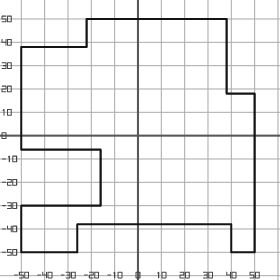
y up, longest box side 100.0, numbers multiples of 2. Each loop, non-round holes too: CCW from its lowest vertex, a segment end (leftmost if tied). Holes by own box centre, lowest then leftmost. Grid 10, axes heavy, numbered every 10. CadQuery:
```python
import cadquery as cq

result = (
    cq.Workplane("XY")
    .moveTo(-50.0, -50.0)
    .lineTo(-26.0, -50.0)
    .lineTo(-26.0, -38.0)
    .lineTo(40.0, -38.0)
    .lineTo(40.0, -50.0)
    .lineTo(50.0, -50.0)
    .lineTo(50.0, 18.0)
    .lineTo(38.0, 18.0)
    .lineTo(38.0, 50.0)
    .lineTo(-22.0, 50.0)
    .lineTo(-22.0, 38.0)
    .lineTo(-50.0, 38.0)
    .lineTo(-50.0, -6.0)
    .lineTo(-16.0, -6.0)
    .lineTo(-16.0, -30.0)
    .lineTo(-50.0, -30.0)
    .close()
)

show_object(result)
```